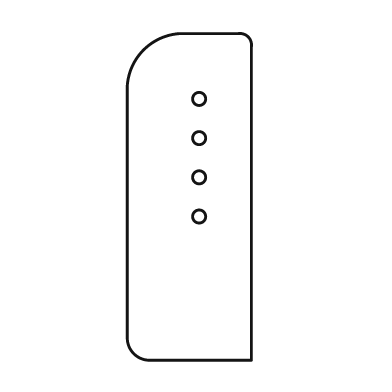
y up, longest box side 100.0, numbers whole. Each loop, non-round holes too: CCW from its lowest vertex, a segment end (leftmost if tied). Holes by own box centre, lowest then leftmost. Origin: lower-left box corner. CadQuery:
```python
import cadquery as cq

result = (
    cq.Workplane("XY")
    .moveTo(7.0, 0.0)
    .lineTo(38.0, 0.0)
    .lineTo(38.0, 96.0)
    .threePointArc((37.0, 99.0), (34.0, 100.0))
    .lineTo(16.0, 100.0)
    .threePointArc((5.0, 95.0), (0.0, 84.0))
    .lineTo(0.0, 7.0)
    .threePointArc((2.0, 2.0), (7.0, 0.0))
    .close()
    .moveTo(22.0, 44.0)
    .circle(2.0)
    .moveTo(22.0, 56.0)
    .circle(2.0)
    .moveTo(22.0, 68.0)
    .circle(2.0)
    .moveTo(22.0, 80.0)
    .circle(2.0)
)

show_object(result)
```